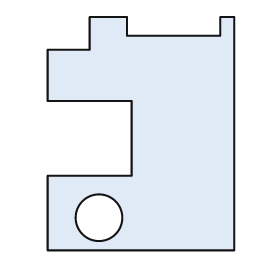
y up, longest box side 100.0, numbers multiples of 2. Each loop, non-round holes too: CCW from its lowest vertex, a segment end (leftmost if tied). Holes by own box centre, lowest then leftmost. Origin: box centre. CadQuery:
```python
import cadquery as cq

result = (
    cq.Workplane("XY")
    .moveTo(-40.0, -50.0)
    .lineTo(40.0, -50.0)
    .lineTo(40.0, 50.0)
    .lineTo(34.0, 50.0)
    .lineTo(34.0, 42.0)
    .lineTo(-6.0, 42.0)
    .lineTo(-6.0, 50.0)
    .lineTo(-22.0, 50.0)
    .lineTo(-22.0, 36.0)
    .lineTo(-40.0, 36.0)
    .lineTo(-40.0, 14.0)
    .lineTo(-4.0, 14.0)
    .lineTo(-4.0, -18.0)
    .lineTo(-40.0, -18.0)
    .close()
    .moveTo(-18.0, -36.0)
    .circle(10.0)
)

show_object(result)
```